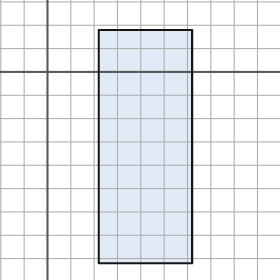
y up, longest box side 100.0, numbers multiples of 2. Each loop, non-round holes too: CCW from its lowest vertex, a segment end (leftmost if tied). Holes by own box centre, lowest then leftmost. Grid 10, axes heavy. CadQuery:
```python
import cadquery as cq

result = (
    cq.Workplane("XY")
    .moveTo(22.0, -82.0)
    .lineTo(62.0, -82.0)
    .lineTo(62.0, 18.0)
    .lineTo(22.0, 18.0)
    .close()
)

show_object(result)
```